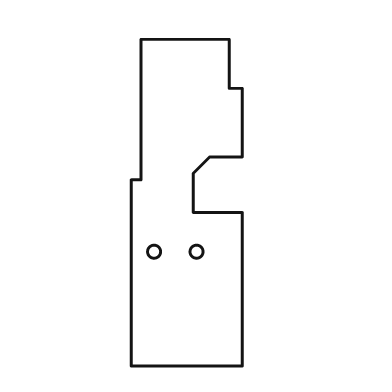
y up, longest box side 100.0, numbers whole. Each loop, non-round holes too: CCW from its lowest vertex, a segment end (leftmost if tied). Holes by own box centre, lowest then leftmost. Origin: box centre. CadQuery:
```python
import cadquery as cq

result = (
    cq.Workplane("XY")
    .moveTo(-17.0, -50.0)
    .lineTo(17.0, -50.0)
    .lineTo(17.0, -3.0)
    .lineTo(2.0, -3.0)
    .lineTo(2.0, 9.0)
    .lineTo(7.0, 14.0)
    .lineTo(17.0, 14.0)
    .lineTo(17.0, 35.0)
    .lineTo(13.0, 35.0)
    .lineTo(13.0, 50.0)
    .lineTo(-14.0, 50.0)
    .lineTo(-14.0, 7.0)
    .lineTo(-17.0, 7.0)
    .close()
    .moveTo(-10.0, -15.0)
    .circle(2.0)
    .moveTo(3.0, -15.0)
    .circle(2.0)
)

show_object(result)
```